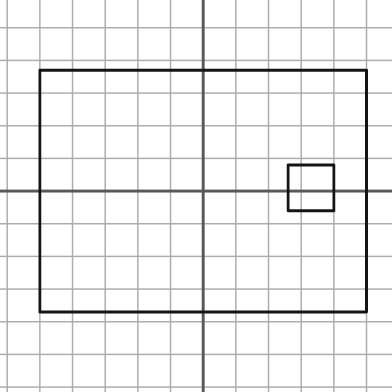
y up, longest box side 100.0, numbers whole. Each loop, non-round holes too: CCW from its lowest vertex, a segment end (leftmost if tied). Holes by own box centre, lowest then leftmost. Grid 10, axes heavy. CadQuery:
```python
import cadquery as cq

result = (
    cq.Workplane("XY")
    .moveTo(-50.0, -37.0)
    .lineTo(50.0, -37.0)
    .lineTo(50.0, 37.0)
    .lineTo(-50.0, 37.0)
    .close()
    .moveTo(26.0, -6.0)
    .lineTo(40.0, -6.0)
    .lineTo(40.0, 8.0)
    .lineTo(26.0, 8.0)
    .close()
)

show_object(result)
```